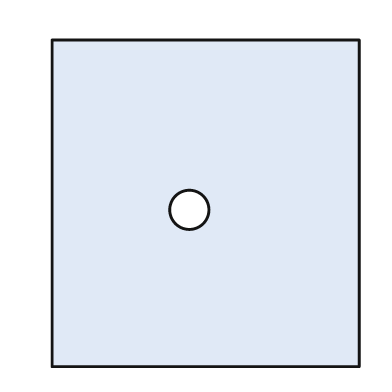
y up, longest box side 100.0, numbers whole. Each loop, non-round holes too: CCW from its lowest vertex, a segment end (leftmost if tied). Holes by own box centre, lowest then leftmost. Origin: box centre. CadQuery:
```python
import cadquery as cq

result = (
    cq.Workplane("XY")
    .moveTo(-47.0, -50.0)
    .lineTo(47.0, -50.0)
    .lineTo(47.0, 50.0)
    .lineTo(-47.0, 50.0)
    .close()
    .moveTo(-5.0, -2.0)
    .circle(6.0)
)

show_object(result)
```